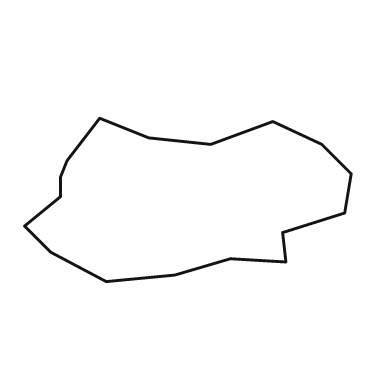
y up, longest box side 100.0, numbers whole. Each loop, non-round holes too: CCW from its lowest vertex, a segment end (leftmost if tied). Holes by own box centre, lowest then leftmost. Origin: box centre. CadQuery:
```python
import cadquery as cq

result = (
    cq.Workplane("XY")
    .moveTo(-25.0, -25.0)
    .lineTo(-4.0, -23.0)
    .lineTo(13.0, -18.0)
    .lineTo(30.0, -19.0)
    .lineTo(29.0, -10.0)
    .lineTo(48.0, -4.0)
    .lineTo(50.0, 8.0)
    .lineTo(41.0, 17.0)
    .lineTo(26.0, 24.0)
    .lineTo(7.0, 17.0)
    .lineTo(-12.0, 19.0)
    .lineTo(-27.0, 25.0)
    .lineTo(-37.0, 12.0)
    .lineTo(-39.0, 7.0)
    .lineTo(-39.0, 1.0)
    .lineTo(-50.0, -8.0)
    .lineTo(-42.0, -16.0)
    .close()
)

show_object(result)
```